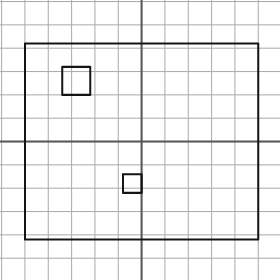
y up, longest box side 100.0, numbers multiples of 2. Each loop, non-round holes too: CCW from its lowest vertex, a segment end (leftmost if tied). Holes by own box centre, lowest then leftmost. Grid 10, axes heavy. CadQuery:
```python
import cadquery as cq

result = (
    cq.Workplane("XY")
    .moveTo(-50.0, -42.0)
    .lineTo(50.0, -42.0)
    .lineTo(50.0, 42.0)
    .lineTo(-50.0, 42.0)
    .close()
    .moveTo(-8.0, -22.0)
    .lineTo(0.0, -22.0)
    .lineTo(0.0, -14.0)
    .lineTo(-8.0, -14.0)
    .close()
    .moveTo(-34.0, 20.0)
    .lineTo(-22.0, 20.0)
    .lineTo(-22.0, 32.0)
    .lineTo(-34.0, 32.0)
    .close()
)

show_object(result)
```